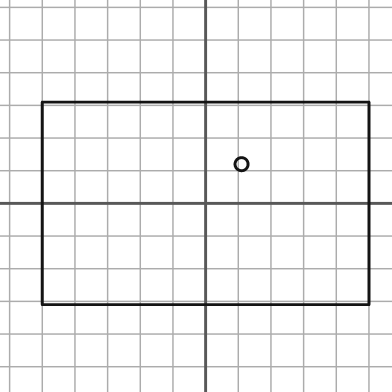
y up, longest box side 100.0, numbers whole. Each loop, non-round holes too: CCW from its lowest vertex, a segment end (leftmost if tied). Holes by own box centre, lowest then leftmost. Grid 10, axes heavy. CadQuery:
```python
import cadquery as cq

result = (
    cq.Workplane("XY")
    .moveTo(-50.0, -31.0)
    .lineTo(50.0, -31.0)
    .lineTo(50.0, 31.0)
    .lineTo(-50.0, 31.0)
    .close()
    .moveTo(11.0, 12.0)
    .circle(2.0)
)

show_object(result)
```